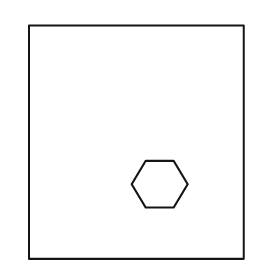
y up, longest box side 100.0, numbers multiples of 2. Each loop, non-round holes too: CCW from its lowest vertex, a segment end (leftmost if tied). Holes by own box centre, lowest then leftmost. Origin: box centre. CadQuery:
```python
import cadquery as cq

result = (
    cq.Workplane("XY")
    .moveTo(-46.0, -50.0)
    .lineTo(46.0, -50.0)
    .lineTo(46.0, 50.0)
    .lineTo(-46.0, 50.0)
    .close()
    .moveTo(4.0, -28.0)
    .lineTo(16.0, -28.0)
    .lineTo(22.0, -18.0)
    .lineTo(16.0, -8.0)
    .lineTo(4.0, -8.0)
    .lineTo(-2.0, -18.0)
    .close()
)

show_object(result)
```